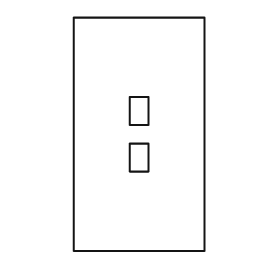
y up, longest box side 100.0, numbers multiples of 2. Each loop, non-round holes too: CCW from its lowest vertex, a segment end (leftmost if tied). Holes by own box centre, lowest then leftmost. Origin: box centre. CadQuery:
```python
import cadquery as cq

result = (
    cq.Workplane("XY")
    .moveTo(-28.0, -50.0)
    .lineTo(28.0, -50.0)
    .lineTo(28.0, 50.0)
    .lineTo(-28.0, 50.0)
    .close()
    .moveTo(-4.0, -16.0)
    .lineTo(4.0, -16.0)
    .lineTo(4.0, -4.0)
    .lineTo(-4.0, -4.0)
    .close()
    .moveTo(-4.0, 4.0)
    .lineTo(4.0, 4.0)
    .lineTo(4.0, 16.0)
    .lineTo(-4.0, 16.0)
    .close()
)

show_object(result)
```